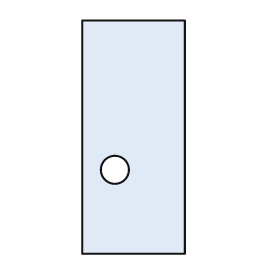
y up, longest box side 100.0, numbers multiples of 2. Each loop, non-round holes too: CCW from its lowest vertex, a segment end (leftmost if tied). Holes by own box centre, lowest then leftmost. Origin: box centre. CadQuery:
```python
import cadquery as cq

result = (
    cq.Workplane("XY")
    .moveTo(-22.0, -50.0)
    .lineTo(22.0, -50.0)
    .lineTo(22.0, 50.0)
    .lineTo(-22.0, 50.0)
    .close()
    .moveTo(-8.0, -14.0)
    .circle(6.0)
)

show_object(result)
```